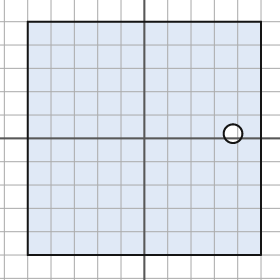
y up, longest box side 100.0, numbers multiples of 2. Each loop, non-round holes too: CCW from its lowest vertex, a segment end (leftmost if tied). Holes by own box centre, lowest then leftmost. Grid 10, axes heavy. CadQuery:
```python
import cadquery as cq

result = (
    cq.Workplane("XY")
    .moveTo(-50.0, -50.0)
    .lineTo(50.0, -50.0)
    .lineTo(50.0, 50.0)
    .lineTo(-50.0, 50.0)
    .close()
    .moveTo(38.0, 2.0)
    .circle(4.0)
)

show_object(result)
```